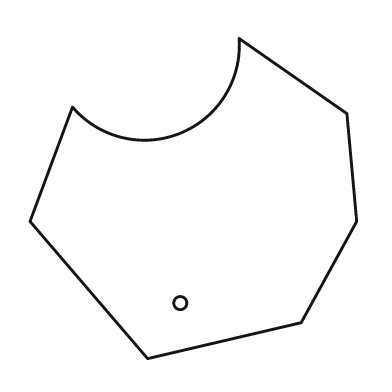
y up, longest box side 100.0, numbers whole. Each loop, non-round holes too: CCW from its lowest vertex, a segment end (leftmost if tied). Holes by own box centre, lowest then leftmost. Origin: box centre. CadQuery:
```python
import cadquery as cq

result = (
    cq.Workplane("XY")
    .moveTo(-14.0, -49.0)
    .lineTo(33.0, -38.0)
    .lineTo(50.0, -7.0)
    .lineTo(47.0, 26.0)
    .lineTo(14.0, 49.0)
    .threePointArc((-4.0, 20.0), (-37.0, 28.0))
    .lineTo(-50.0, -7.0)
    .close()
    .moveTo(-4.0, -32.0)
    .circle(2.0)
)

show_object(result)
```